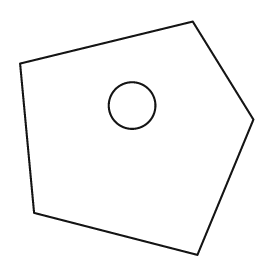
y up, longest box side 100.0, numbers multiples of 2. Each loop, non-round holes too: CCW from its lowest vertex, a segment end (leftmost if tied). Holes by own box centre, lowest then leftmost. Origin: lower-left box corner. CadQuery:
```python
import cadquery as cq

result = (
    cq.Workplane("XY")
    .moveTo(76.0, 0.0)
    .lineTo(100.0, 58.0)
    .lineTo(74.0, 100.0)
    .lineTo(0.0, 82.0)
    .lineTo(6.0, 18.0)
    .close()
    .moveTo(48.0, 64.0)
    .circle(10.0)
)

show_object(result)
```